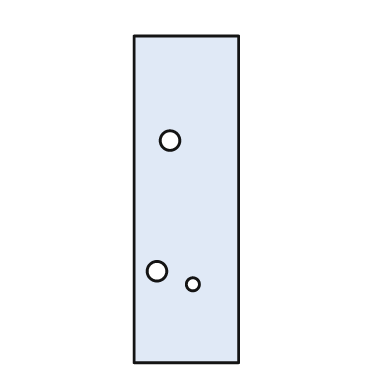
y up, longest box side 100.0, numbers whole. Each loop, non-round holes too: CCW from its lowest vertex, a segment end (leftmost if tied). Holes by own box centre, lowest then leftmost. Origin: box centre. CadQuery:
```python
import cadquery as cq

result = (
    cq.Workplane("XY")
    .moveTo(-16.0, -50.0)
    .lineTo(16.0, -50.0)
    .lineTo(16.0, 50.0)
    .lineTo(-16.0, 50.0)
    .close()
    .moveTo(2.0, -26.0)
    .circle(2.0)
    .moveTo(-9.0, -22.0)
    .circle(3.0)
    .moveTo(-5.0, 18.0)
    .circle(3.0)
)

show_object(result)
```